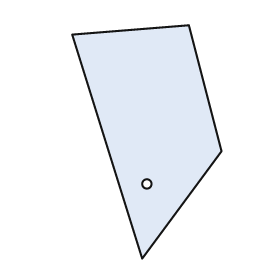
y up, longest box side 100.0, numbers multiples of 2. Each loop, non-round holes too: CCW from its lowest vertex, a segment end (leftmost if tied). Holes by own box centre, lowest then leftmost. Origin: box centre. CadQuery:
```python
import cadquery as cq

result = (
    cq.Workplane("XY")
    .moveTo(-2.0, -50.0)
    .lineTo(32.0, -4.0)
    .lineTo(18.0, 50.0)
    .lineTo(-32.0, 46.0)
    .close()
    .moveTo(0.0, -18.0)
    .circle(2.0)
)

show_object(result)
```